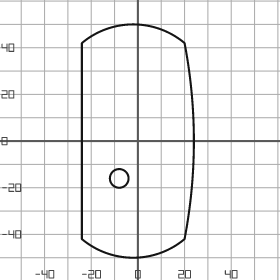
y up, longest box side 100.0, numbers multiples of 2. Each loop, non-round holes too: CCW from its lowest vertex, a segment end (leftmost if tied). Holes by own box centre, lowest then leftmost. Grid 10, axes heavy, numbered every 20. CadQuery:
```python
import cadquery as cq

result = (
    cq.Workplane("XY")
    .moveTo(-24.0, -42.0)
    .threePointArc((-2.0, -50.0), (20.0, -42.0))
    .threePointArc((24.0, 0.0), (20.0, 42.0))
    .threePointArc((-2.0, 50.0), (-24.0, 42.0))
    .close()
    .moveTo(-8.0, -16.0)
    .circle(4.0)
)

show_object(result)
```